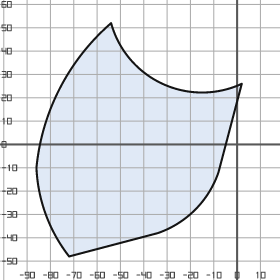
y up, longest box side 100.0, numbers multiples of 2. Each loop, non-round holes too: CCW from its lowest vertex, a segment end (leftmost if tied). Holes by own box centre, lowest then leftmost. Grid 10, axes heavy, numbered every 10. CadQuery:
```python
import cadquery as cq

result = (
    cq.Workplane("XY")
    .moveTo(-72.0, -48.0)
    .lineTo(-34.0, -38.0)
    .threePointArc((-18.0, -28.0), (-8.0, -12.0))
    .lineTo(2.0, 26.0)
    .threePointArc((-32.0, 26.0), (-54.0, 52.0))
    .threePointArc((-76.0, 24.0), (-86.0, -10.0))
    .threePointArc((-82.0, -30.0), (-72.0, -48.0))
    .close()
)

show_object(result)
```